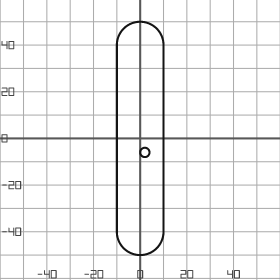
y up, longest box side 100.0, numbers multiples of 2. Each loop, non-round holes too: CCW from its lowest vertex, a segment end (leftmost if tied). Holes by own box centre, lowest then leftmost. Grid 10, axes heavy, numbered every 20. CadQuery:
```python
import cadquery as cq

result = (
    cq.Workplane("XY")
    .moveTo(-10.0, -40.0)
    .threePointArc((0.0, -50.0), (10.0, -40.0))
    .lineTo(10.0, 40.0)
    .threePointArc((0.0, 50.0), (-10.0, 40.0))
    .close()
    .moveTo(2.0, -6.0)
    .circle(2.0)
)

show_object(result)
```